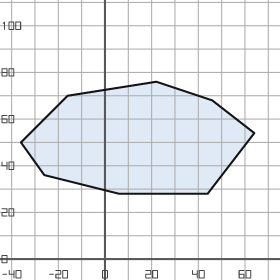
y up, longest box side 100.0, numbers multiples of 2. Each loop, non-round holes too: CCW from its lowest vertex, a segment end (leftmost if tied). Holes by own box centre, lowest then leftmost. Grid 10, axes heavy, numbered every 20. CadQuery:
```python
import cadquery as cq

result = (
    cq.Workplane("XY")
    .moveTo(6.0, 28.0)
    .lineTo(44.0, 28.0)
    .lineTo(64.0, 54.0)
    .lineTo(46.0, 68.0)
    .lineTo(22.0, 76.0)
    .lineTo(-16.0, 70.0)
    .lineTo(-36.0, 50.0)
    .lineTo(-26.0, 36.0)
    .close()
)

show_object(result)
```